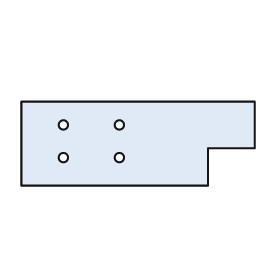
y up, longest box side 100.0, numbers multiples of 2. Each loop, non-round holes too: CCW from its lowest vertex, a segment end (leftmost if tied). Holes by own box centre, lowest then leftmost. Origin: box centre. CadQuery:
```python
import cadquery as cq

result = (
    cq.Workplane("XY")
    .moveTo(-50.0, -18.0)
    .lineTo(30.0, -18.0)
    .lineTo(30.0, -2.0)
    .lineTo(50.0, -2.0)
    .lineTo(50.0, 18.0)
    .lineTo(-50.0, 18.0)
    .close()
    .moveTo(-32.0, -6.0)
    .circle(2.0)
    .moveTo(-8.0, -6.0)
    .circle(2.0)
    .moveTo(-32.0, 8.0)
    .circle(2.0)
    .moveTo(-8.0, 8.0)
    .circle(2.0)
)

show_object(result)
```